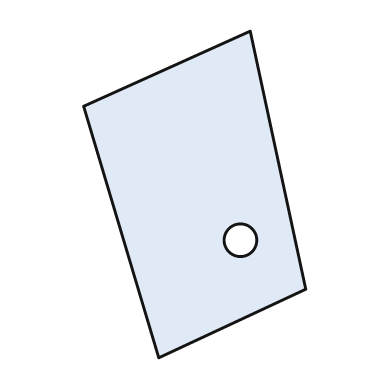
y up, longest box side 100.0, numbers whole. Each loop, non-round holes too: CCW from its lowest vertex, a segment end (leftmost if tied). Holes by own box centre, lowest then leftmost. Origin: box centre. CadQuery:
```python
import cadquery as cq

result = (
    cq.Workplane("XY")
    .moveTo(-11.0, -50.0)
    .lineTo(34.0, -29.0)
    .lineTo(17.0, 50.0)
    .lineTo(-34.0, 27.0)
    .close()
    .moveTo(14.0, -14.0)
    .circle(5.0)
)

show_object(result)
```